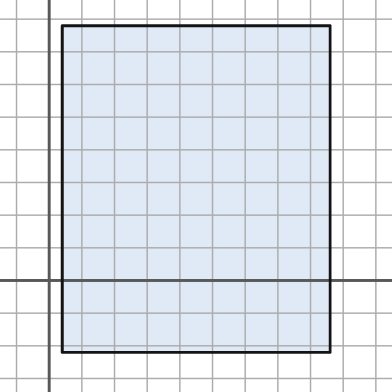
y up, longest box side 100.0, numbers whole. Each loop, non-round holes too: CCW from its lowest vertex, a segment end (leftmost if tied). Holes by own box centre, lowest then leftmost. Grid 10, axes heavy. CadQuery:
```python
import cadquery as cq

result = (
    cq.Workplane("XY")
    .moveTo(4.0, -22.0)
    .lineTo(86.0, -22.0)
    .lineTo(86.0, 78.0)
    .lineTo(4.0, 78.0)
    .close()
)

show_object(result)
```